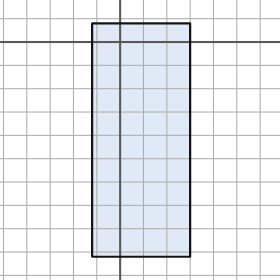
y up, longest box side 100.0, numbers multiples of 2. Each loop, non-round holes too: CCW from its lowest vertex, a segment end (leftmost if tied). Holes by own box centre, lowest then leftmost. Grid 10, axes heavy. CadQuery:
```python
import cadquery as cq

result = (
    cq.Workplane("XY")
    .moveTo(-12.0, -92.0)
    .lineTo(30.0, -92.0)
    .lineTo(30.0, 8.0)
    .lineTo(-12.0, 8.0)
    .close()
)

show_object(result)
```